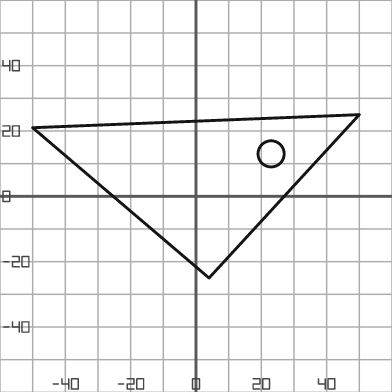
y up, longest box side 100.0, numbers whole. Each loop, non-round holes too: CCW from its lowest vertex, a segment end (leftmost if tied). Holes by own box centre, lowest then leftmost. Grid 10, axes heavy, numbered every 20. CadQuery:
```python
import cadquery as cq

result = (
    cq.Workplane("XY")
    .moveTo(4.0, -25.0)
    .lineTo(50.0, 25.0)
    .lineTo(-50.0, 21.0)
    .close()
    .moveTo(23.0, 13.0)
    .circle(4.0)
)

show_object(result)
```